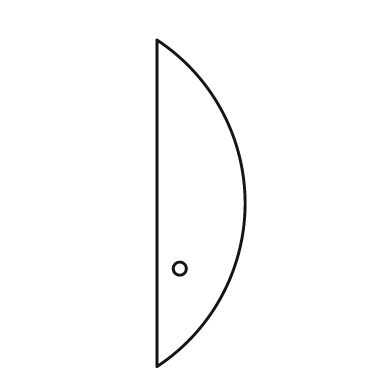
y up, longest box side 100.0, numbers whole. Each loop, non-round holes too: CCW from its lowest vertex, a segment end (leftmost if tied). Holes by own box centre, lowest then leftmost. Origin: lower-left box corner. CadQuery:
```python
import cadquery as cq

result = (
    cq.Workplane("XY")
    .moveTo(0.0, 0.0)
    .threePointArc((27.0, 50.0), (0.0, 100.0))
    .close()
    .moveTo(7.0, 30.0)
    .circle(2.0)
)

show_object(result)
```